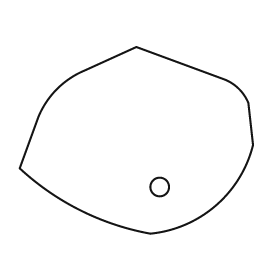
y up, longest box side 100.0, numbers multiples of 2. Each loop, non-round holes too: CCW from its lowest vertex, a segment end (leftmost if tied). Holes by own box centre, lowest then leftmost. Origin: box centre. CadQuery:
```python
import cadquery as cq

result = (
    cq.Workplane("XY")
    .moveTo(6.0, -40.0)
    .threePointArc((34.0, -28.0), (50.0, -2.0))
    .lineTo(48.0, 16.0)
    .threePointArc((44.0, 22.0), (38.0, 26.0))
    .lineTo(0.0, 40.0)
    .lineTo(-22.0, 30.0)
    .threePointArc((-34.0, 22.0), (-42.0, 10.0))
    .lineTo(-50.0, -12.0)
    .threePointArc((-24.0, -30.0), (6.0, -40.0))
    .close()
    .moveTo(10.0, -20.0)
    .circle(4.0)
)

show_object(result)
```